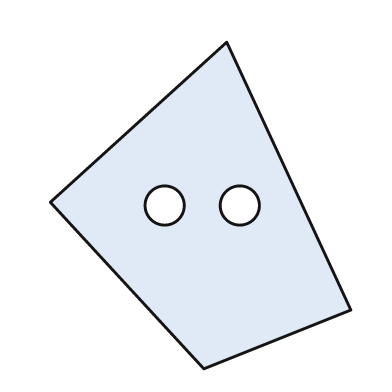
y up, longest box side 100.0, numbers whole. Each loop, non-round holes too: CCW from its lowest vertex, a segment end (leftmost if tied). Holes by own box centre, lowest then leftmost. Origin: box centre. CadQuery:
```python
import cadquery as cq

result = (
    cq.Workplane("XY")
    .moveTo(1.0, -50.0)
    .lineTo(46.0, -32.0)
    .lineTo(8.0, 50.0)
    .lineTo(-46.0, 1.0)
    .close()
    .moveTo(-11.0, 0.0)
    .circle(6.0)
    .moveTo(12.0, 0.0)
    .circle(6.0)
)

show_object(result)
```